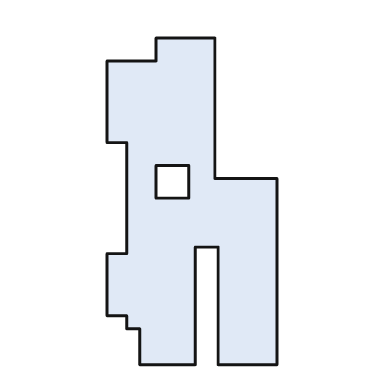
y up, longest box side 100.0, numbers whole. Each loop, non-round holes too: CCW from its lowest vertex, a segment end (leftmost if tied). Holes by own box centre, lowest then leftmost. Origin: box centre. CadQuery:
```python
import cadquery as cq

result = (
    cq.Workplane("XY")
    .moveTo(-16.0, -50.0)
    .lineTo(1.0, -50.0)
    .lineTo(1.0, -14.0)
    .lineTo(8.0, -14.0)
    .lineTo(8.0, -50.0)
    .lineTo(26.0, -50.0)
    .lineTo(26.0, 7.0)
    .lineTo(7.0, 7.0)
    .lineTo(7.0, 50.0)
    .lineTo(-11.0, 50.0)
    .lineTo(-11.0, 43.0)
    .lineTo(-26.0, 43.0)
    .lineTo(-26.0, 18.0)
    .lineTo(-20.0, 18.0)
    .lineTo(-20.0, -16.0)
    .lineTo(-26.0, -16.0)
    .lineTo(-26.0, -35.0)
    .lineTo(-20.0, -35.0)
    .lineTo(-20.0, -39.0)
    .lineTo(-16.0, -39.0)
    .close()
    .moveTo(-11.0, 1.0)
    .lineTo(-1.0, 1.0)
    .lineTo(-1.0, 11.0)
    .lineTo(-11.0, 11.0)
    .close()
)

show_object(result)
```